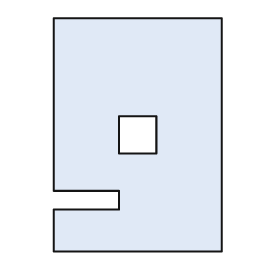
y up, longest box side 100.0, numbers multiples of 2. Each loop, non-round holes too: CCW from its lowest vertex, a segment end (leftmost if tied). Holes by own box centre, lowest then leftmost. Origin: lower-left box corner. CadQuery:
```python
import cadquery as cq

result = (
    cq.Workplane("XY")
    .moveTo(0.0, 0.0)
    .lineTo(72.0, 0.0)
    .lineTo(72.0, 100.0)
    .lineTo(0.0, 100.0)
    .lineTo(0.0, 26.0)
    .lineTo(28.0, 26.0)
    .lineTo(28.0, 18.0)
    .lineTo(0.0, 18.0)
    .close()
    .moveTo(28.0, 42.0)
    .lineTo(44.0, 42.0)
    .lineTo(44.0, 58.0)
    .lineTo(28.0, 58.0)
    .close()
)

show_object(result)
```